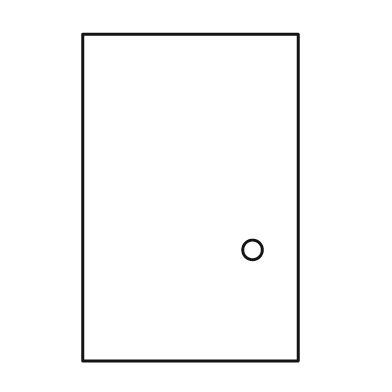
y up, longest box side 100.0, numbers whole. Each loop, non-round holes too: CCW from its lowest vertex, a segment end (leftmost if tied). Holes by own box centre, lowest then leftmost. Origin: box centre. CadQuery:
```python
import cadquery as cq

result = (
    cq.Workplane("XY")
    .moveTo(-33.0, -50.0)
    .lineTo(33.0, -50.0)
    .lineTo(33.0, 50.0)
    .lineTo(-33.0, 50.0)
    .close()
    .moveTo(19.0, -16.0)
    .circle(3.0)
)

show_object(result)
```